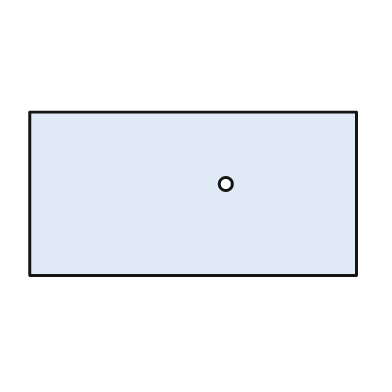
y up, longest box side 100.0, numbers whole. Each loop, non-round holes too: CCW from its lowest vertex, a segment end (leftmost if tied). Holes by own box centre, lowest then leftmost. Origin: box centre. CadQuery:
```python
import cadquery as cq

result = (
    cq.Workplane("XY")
    .moveTo(-50.0, -25.0)
    .lineTo(50.0, -25.0)
    .lineTo(50.0, 25.0)
    .lineTo(-50.0, 25.0)
    .close()
    .moveTo(10.0, 3.0)
    .circle(2.0)
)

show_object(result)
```